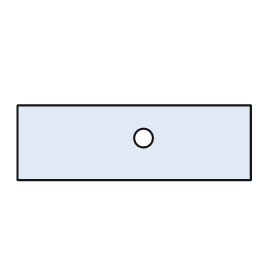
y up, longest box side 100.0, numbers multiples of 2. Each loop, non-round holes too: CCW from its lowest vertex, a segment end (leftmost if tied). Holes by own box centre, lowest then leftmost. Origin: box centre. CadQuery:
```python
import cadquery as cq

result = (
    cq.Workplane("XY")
    .moveTo(-50.0, -16.0)
    .lineTo(50.0, -16.0)
    .lineTo(50.0, 16.0)
    .lineTo(-50.0, 16.0)
    .close()
    .moveTo(4.0, 2.0)
    .circle(4.0)
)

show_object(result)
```